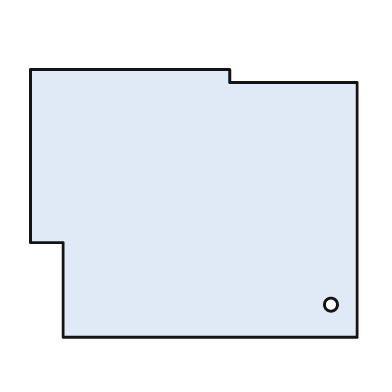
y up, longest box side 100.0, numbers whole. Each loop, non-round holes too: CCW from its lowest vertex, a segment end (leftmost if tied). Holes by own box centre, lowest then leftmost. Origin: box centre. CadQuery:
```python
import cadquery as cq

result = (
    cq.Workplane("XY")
    .moveTo(-40.0, -41.0)
    .lineTo(50.0, -41.0)
    .lineTo(50.0, 37.0)
    .lineTo(11.0, 37.0)
    .lineTo(11.0, 41.0)
    .lineTo(-50.0, 41.0)
    .lineTo(-50.0, -12.0)
    .lineTo(-40.0, -12.0)
    .close()
    .moveTo(42.0, -31.0)
    .circle(2.0)
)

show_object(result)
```